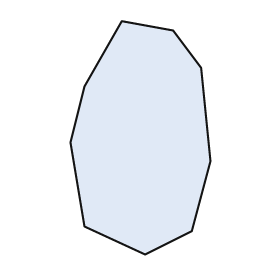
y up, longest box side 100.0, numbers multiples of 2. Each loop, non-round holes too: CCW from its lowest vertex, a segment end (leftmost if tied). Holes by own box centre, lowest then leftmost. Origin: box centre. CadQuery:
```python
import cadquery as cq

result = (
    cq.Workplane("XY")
    .moveTo(2.0, -50.0)
    .lineTo(22.0, -40.0)
    .lineTo(30.0, -10.0)
    .lineTo(26.0, 30.0)
    .lineTo(14.0, 46.0)
    .lineTo(-8.0, 50.0)
    .lineTo(-24.0, 22.0)
    .lineTo(-30.0, -2.0)
    .lineTo(-24.0, -38.0)
    .close()
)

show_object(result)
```